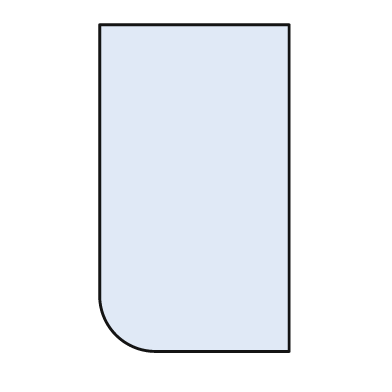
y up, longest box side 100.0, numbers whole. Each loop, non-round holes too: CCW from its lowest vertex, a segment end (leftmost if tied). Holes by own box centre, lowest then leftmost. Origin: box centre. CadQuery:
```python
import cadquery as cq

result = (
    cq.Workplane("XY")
    .moveTo(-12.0, -50.0)
    .lineTo(29.0, -50.0)
    .lineTo(29.0, 50.0)
    .lineTo(-29.0, 50.0)
    .lineTo(-29.0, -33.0)
    .threePointArc((-24.0, -45.0), (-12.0, -50.0))
    .close()
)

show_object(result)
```